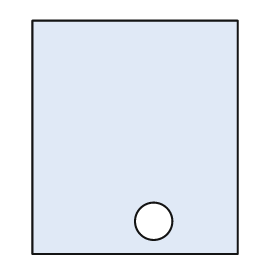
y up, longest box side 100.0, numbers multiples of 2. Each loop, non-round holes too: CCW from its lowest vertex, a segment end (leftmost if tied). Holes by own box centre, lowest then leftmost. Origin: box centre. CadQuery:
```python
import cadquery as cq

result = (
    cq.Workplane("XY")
    .moveTo(-44.0, -50.0)
    .lineTo(44.0, -50.0)
    .lineTo(44.0, 50.0)
    .lineTo(-44.0, 50.0)
    .close()
    .moveTo(8.0, -36.0)
    .circle(8.0)
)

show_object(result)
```